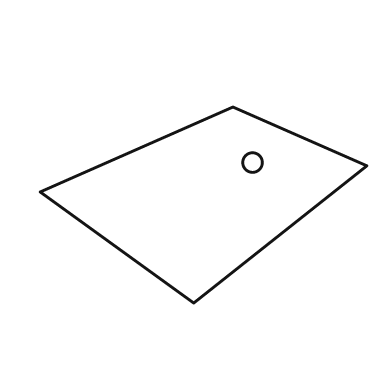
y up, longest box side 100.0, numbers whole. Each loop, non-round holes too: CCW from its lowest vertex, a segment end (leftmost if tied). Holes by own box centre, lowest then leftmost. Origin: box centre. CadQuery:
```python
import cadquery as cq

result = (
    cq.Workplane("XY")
    .moveTo(-3.0, -30.0)
    .lineTo(50.0, 12.0)
    .lineTo(9.0, 30.0)
    .lineTo(-50.0, 4.0)
    .close()
    .moveTo(15.0, 13.0)
    .circle(3.0)
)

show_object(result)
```